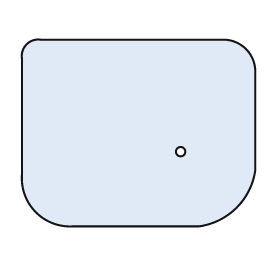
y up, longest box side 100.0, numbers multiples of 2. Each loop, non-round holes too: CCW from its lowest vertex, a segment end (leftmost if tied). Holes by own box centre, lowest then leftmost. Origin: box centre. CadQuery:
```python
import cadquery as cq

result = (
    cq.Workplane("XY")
    .moveTo(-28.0, -40.0)
    .lineTo(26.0, -40.0)
    .threePointArc((42.0, -32.0), (50.0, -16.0))
    .lineTo(50.0, 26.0)
    .threePointArc((46.0, 36.0), (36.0, 40.0))
    .lineTo(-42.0, 40.0)
    .threePointArc((-48.0, 38.0), (-50.0, 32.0))
    .lineTo(-50.0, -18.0)
    .threePointArc((-44.0, -34.0), (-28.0, -40.0))
    .close()
    .moveTo(18.0, -8.0)
    .circle(2.0)
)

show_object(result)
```